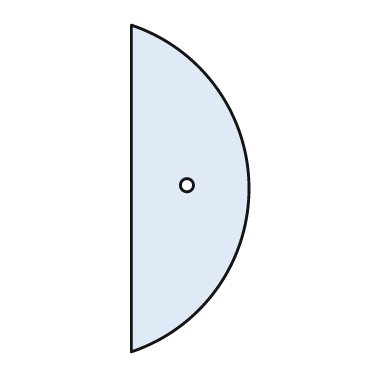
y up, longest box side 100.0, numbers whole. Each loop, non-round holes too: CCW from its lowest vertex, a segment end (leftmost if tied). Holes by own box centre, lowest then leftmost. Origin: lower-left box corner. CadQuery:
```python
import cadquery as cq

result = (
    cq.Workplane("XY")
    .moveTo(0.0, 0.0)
    .threePointArc((36.0, 50.0), (0.0, 100.0))
    .close()
    .moveTo(17.0, 51.0)
    .circle(2.0)
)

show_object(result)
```